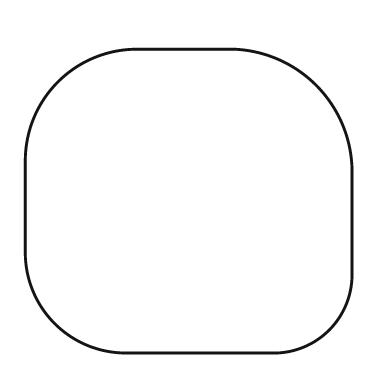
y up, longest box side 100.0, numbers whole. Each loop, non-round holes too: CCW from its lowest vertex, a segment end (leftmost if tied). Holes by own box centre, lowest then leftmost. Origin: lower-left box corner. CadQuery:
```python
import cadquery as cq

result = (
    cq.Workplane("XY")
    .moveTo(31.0, 0.0)
    .lineTo(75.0, 0.0)
    .threePointArc((93.0, 7.0), (100.0, 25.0))
    .lineTo(100.0, 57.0)
    .threePointArc((89.0, 82.0), (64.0, 93.0))
    .lineTo(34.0, 93.0)
    .threePointArc((10.0, 83.0), (0.0, 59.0))
    .lineTo(0.0, 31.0)
    .threePointArc((9.0, 9.0), (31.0, 0.0))
    .close()
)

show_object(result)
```